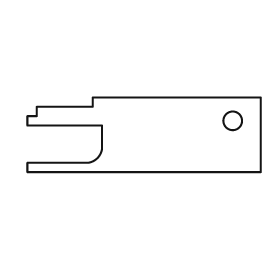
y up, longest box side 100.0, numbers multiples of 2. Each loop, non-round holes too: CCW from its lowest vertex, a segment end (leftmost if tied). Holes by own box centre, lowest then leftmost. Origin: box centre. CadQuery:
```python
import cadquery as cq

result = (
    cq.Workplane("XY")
    .moveTo(-50.0, -16.0)
    .lineTo(50.0, -16.0)
    .lineTo(50.0, 16.0)
    .lineTo(-22.0, 16.0)
    .lineTo(-22.0, 12.0)
    .lineTo(-46.0, 12.0)
    .lineTo(-46.0, 8.0)
    .lineTo(-50.0, 8.0)
    .lineTo(-50.0, 4.0)
    .lineTo(-18.0, 4.0)
    .lineTo(-18.0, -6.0)
    .threePointArc((-20.0, -10.0), (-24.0, -12.0))
    .lineTo(-50.0, -12.0)
    .close()
    .moveTo(38.0, 6.0)
    .circle(4.0)
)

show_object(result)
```